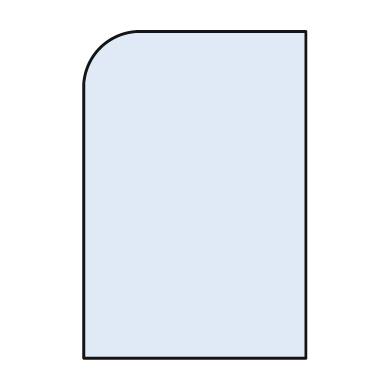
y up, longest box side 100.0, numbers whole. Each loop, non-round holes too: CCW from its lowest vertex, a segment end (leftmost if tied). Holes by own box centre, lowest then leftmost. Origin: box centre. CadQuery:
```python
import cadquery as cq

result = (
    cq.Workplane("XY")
    .moveTo(-34.0, -50.0)
    .lineTo(34.0, -50.0)
    .lineTo(34.0, 50.0)
    .lineTo(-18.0, 50.0)
    .threePointArc((-29.0, 45.0), (-34.0, 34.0))
    .close()
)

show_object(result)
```